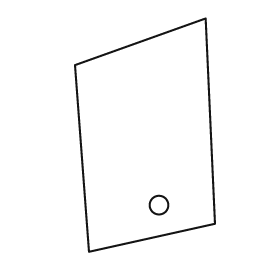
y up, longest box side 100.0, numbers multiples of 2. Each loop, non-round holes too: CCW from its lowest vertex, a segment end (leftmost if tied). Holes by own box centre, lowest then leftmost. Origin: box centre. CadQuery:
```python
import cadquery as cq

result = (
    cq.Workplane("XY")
    .moveTo(-24.0, -50.0)
    .lineTo(30.0, -38.0)
    .lineTo(26.0, 50.0)
    .lineTo(-30.0, 30.0)
    .close()
    .moveTo(6.0, -30.0)
    .circle(4.0)
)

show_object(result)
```